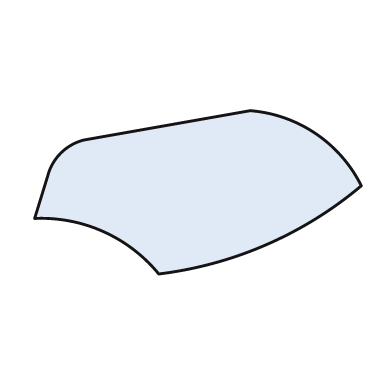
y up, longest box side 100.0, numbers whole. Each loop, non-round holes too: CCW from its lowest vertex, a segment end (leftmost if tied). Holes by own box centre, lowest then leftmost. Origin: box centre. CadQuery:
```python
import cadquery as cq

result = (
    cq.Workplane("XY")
    .moveTo(-12.0, -25.0)
    .threePointArc((21.0, -16.0), (50.0, 2.0))
    .threePointArc((36.0, 18.0), (16.0, 25.0))
    .lineTo(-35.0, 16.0)
    .threePointArc((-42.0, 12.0), (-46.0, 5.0))
    .lineTo(-50.0, -8.0)
    .threePointArc((-29.0, -12.0), (-12.0, -25.0))
    .close()
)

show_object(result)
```